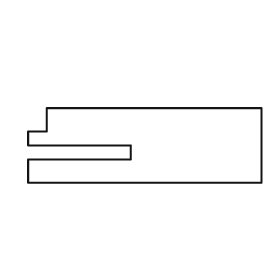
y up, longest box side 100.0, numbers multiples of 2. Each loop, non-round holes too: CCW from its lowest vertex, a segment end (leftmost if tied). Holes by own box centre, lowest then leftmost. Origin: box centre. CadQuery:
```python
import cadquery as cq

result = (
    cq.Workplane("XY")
    .moveTo(-50.0, -16.0)
    .lineTo(50.0, -16.0)
    .lineTo(50.0, 16.0)
    .lineTo(-42.0, 16.0)
    .lineTo(-42.0, 6.0)
    .lineTo(-50.0, 6.0)
    .lineTo(-50.0, 0.0)
    .lineTo(-6.0, 0.0)
    .lineTo(-6.0, -6.0)
    .lineTo(-50.0, -6.0)
    .close()
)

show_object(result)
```